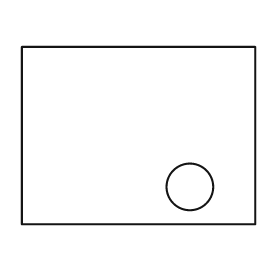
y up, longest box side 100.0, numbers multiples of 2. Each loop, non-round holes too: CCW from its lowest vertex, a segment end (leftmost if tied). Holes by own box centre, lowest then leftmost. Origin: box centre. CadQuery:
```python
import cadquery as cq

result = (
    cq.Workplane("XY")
    .moveTo(-50.0, -38.0)
    .lineTo(50.0, -38.0)
    .lineTo(50.0, 38.0)
    .lineTo(-50.0, 38.0)
    .close()
    .moveTo(22.0, -22.0)
    .circle(10.0)
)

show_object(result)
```